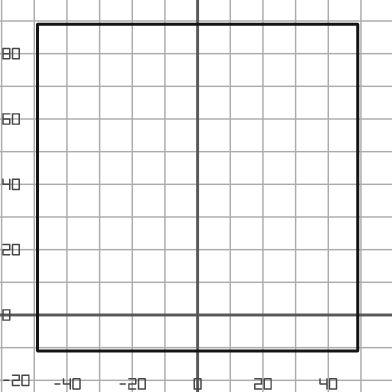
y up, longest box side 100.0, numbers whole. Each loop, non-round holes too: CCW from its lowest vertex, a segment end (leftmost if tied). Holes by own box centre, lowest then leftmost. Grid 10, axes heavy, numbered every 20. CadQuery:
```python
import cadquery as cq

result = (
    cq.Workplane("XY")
    .moveTo(-49.0, -11.0)
    .lineTo(49.0, -11.0)
    .lineTo(49.0, 89.0)
    .lineTo(-49.0, 89.0)
    .close()
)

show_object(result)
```